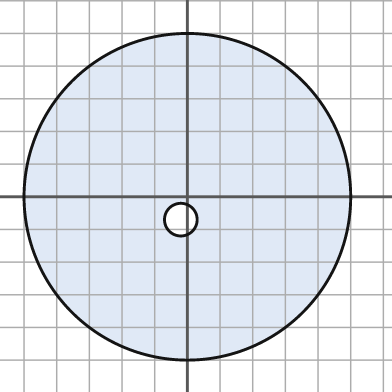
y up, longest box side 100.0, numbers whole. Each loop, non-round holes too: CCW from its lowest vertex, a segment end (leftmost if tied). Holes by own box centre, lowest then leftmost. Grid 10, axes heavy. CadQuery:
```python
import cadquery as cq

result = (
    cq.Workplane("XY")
    .moveTo(0.0, 0.0)
    .circle(50.0)
    .moveTo(-2.0, -7.0)
    .circle(5.0)
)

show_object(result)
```